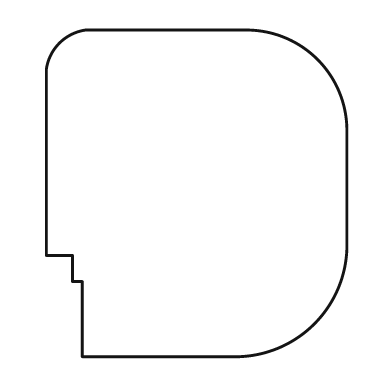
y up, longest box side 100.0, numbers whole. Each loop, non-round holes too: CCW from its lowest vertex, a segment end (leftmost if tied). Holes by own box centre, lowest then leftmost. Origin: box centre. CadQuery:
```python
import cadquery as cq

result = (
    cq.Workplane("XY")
    .moveTo(-35.0, -50.0)
    .lineTo(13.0, -50.0)
    .threePointArc((36.0, -40.0), (46.0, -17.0))
    .lineTo(46.0, 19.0)
    .threePointArc((37.0, 41.0), (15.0, 50.0))
    .lineTo(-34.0, 50.0)
    .threePointArc((-42.0, 46.0), (-46.0, 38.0))
    .lineTo(-46.0, -19.0)
    .lineTo(-38.0, -19.0)
    .lineTo(-38.0, -27.0)
    .lineTo(-35.0, -27.0)
    .close()
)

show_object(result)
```